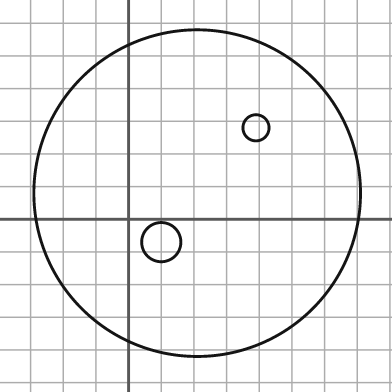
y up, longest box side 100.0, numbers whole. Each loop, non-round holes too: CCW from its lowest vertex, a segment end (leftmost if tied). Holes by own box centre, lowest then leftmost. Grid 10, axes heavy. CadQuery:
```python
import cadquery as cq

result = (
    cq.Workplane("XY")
    .moveTo(21.0, 8.0)
    .circle(50.0)
    .moveTo(10.0, -7.0)
    .circle(6.0)
    .moveTo(39.0, 28.0)
    .circle(4.0)
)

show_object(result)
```